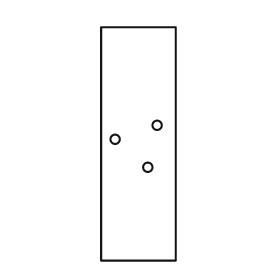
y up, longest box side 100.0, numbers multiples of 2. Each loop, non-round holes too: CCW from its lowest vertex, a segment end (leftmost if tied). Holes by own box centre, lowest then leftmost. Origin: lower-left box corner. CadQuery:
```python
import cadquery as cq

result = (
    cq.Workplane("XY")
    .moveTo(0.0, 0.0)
    .lineTo(32.0, 0.0)
    .lineTo(32.0, 100.0)
    .lineTo(0.0, 100.0)
    .close()
    .moveTo(20.0, 40.0)
    .circle(2.0)
    .moveTo(6.0, 52.0)
    .circle(2.0)
    .moveTo(24.0, 58.0)
    .circle(2.0)
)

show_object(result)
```